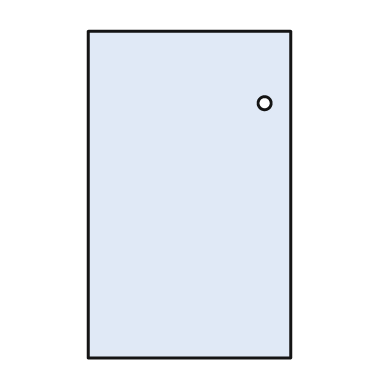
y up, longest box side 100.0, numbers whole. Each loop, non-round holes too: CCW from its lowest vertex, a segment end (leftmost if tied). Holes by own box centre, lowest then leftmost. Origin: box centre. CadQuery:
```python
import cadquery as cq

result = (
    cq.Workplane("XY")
    .moveTo(-31.0, -50.0)
    .lineTo(31.0, -50.0)
    .lineTo(31.0, 50.0)
    .lineTo(-31.0, 50.0)
    .close()
    .moveTo(23.0, 28.0)
    .circle(2.0)
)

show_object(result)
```